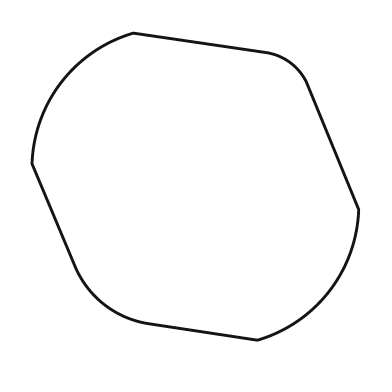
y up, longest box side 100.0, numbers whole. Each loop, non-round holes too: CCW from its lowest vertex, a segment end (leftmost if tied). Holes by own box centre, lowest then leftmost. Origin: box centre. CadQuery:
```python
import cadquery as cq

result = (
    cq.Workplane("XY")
    .moveTo(19.0, -47.0)
    .threePointArc((41.0, -32.0), (50.0, -7.0))
    .lineTo(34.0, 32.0)
    .threePointArc((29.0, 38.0), (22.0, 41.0))
    .lineTo(-19.0, 47.0)
    .threePointArc((-41.0, 32.0), (-50.0, 7.0))
    .lineTo(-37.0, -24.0)
    .threePointArc((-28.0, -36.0), (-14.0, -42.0))
    .close()
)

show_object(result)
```